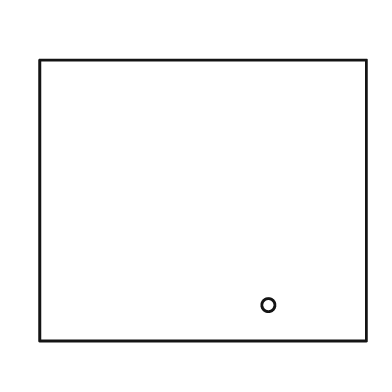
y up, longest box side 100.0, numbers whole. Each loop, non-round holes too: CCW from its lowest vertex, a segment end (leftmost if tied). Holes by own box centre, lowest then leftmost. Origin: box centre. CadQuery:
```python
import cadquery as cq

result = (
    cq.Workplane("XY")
    .moveTo(-50.0, -43.0)
    .lineTo(50.0, -43.0)
    .lineTo(50.0, 43.0)
    .lineTo(-50.0, 43.0)
    .close()
    .moveTo(20.0, -32.0)
    .circle(2.0)
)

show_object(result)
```